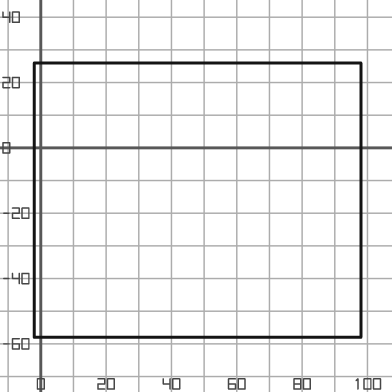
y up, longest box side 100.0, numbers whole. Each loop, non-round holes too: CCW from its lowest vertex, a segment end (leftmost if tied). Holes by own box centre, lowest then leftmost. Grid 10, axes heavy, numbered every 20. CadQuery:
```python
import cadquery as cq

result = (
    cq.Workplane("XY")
    .moveTo(-2.0, -58.0)
    .lineTo(98.0, -58.0)
    .lineTo(98.0, 26.0)
    .lineTo(-2.0, 26.0)
    .close()
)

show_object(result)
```